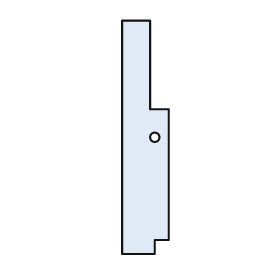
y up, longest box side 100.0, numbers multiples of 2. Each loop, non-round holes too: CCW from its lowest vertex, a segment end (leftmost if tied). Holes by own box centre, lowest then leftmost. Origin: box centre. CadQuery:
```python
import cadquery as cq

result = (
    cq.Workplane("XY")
    .moveTo(-10.0, -50.0)
    .lineTo(4.0, -50.0)
    .lineTo(4.0, -44.0)
    .lineTo(10.0, -44.0)
    .lineTo(10.0, 12.0)
    .lineTo(2.0, 12.0)
    .lineTo(2.0, 50.0)
    .lineTo(-10.0, 50.0)
    .close()
    .moveTo(4.0, 0.0)
    .circle(2.0)
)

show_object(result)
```